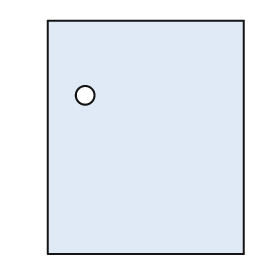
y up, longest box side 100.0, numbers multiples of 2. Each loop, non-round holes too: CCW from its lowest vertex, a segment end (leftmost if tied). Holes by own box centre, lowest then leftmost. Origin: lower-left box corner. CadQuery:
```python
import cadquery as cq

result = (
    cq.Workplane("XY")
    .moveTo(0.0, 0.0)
    .lineTo(84.0, 0.0)
    .lineTo(84.0, 100.0)
    .lineTo(0.0, 100.0)
    .close()
    .moveTo(16.0, 68.0)
    .circle(4.0)
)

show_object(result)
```